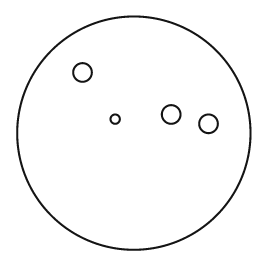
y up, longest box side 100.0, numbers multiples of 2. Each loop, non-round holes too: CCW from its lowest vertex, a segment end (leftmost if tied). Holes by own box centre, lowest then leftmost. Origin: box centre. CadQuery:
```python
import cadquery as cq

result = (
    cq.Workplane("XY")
    .moveTo(0.0, 0.0)
    .circle(50.0)
    .moveTo(32.0, 4.0)
    .circle(4.0)
    .moveTo(-8.0, 6.0)
    .circle(2.0)
    .moveTo(16.0, 8.0)
    .circle(4.0)
    .moveTo(-22.0, 26.0)
    .circle(4.0)
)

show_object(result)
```